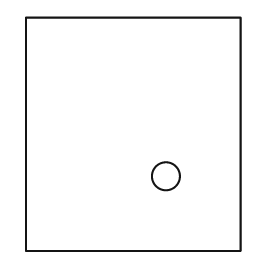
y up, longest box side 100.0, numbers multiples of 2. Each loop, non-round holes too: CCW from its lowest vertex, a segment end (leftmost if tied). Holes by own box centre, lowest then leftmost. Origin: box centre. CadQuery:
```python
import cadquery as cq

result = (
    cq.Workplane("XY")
    .moveTo(-46.0, -50.0)
    .lineTo(46.0, -50.0)
    .lineTo(46.0, 50.0)
    .lineTo(-46.0, 50.0)
    .close()
    .moveTo(14.0, -18.0)
    .circle(6.0)
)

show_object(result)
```